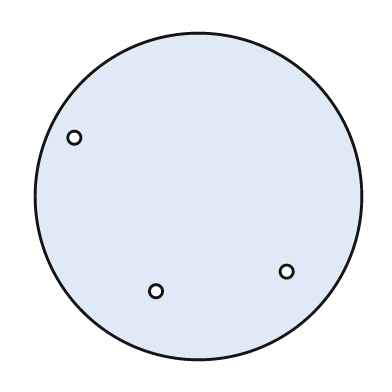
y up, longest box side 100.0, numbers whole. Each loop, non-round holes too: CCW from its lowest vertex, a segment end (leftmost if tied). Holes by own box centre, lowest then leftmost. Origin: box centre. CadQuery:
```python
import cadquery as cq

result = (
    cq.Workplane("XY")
    .moveTo(0.0, 0.0)
    .circle(50.0)
    .moveTo(-13.0, -29.0)
    .circle(2.0)
    .moveTo(27.0, -23.0)
    .circle(2.0)
    .moveTo(-38.0, 18.0)
    .circle(2.0)
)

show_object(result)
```